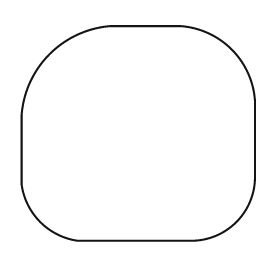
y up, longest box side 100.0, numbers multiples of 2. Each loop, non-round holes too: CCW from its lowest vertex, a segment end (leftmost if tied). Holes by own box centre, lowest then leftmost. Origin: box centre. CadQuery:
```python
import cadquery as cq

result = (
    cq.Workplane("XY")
    .moveTo(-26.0, -46.0)
    .lineTo(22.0, -46.0)
    .threePointArc((42.0, -38.0), (50.0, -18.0))
    .lineTo(50.0, 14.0)
    .threePointArc((40.0, 36.0), (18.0, 46.0))
    .lineTo(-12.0, 46.0)
    .threePointArc((-38.0, 34.0), (-50.0, 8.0))
    .lineTo(-50.0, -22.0)
    .threePointArc((-42.0, -38.0), (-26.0, -46.0))
    .close()
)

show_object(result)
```